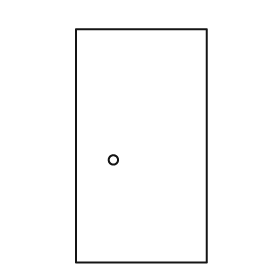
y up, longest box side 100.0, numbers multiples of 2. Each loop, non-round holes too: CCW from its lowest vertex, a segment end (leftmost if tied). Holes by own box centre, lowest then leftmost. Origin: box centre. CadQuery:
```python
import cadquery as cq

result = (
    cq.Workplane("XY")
    .moveTo(-28.0, -50.0)
    .lineTo(28.0, -50.0)
    .lineTo(28.0, 50.0)
    .lineTo(-28.0, 50.0)
    .close()
    .moveTo(-12.0, -6.0)
    .circle(2.0)
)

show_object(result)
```